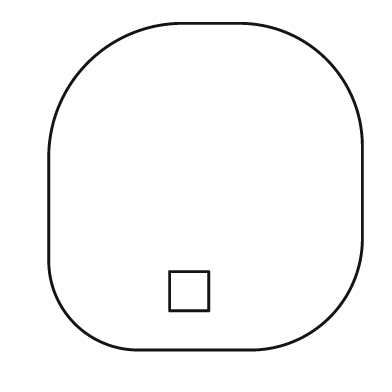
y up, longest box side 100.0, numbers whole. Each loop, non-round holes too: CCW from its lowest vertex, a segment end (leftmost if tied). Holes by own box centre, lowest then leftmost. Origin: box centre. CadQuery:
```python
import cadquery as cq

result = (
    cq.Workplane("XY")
    .moveTo(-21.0, -50.0)
    .lineTo(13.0, -50.0)
    .threePointArc((38.0, -40.0), (48.0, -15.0))
    .lineTo(48.0, 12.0)
    .threePointArc((37.0, 39.0), (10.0, 50.0))
    .lineTo(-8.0, 50.0)
    .threePointArc((-36.0, 38.0), (-48.0, 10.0))
    .lineTo(-48.0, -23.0)
    .threePointArc((-40.0, -42.0), (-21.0, -50.0))
    .close()
    .moveTo(-11.0, -38.0)
    .lineTo(1.0, -38.0)
    .lineTo(1.0, -26.0)
    .lineTo(-11.0, -26.0)
    .close()
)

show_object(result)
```